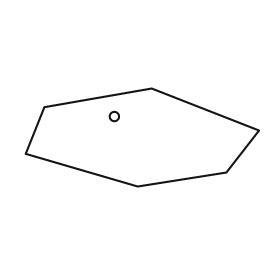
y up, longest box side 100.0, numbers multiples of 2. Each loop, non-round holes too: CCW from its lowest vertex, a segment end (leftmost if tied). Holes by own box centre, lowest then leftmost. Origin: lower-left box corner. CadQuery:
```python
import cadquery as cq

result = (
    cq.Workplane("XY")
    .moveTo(48.0, 0.0)
    .lineTo(86.0, 6.0)
    .lineTo(100.0, 24.0)
    .lineTo(54.0, 42.0)
    .lineTo(8.0, 34.0)
    .lineTo(0.0, 14.0)
    .close()
    .moveTo(38.0, 30.0)
    .circle(2.0)
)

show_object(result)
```